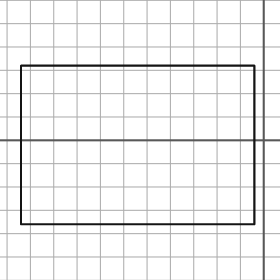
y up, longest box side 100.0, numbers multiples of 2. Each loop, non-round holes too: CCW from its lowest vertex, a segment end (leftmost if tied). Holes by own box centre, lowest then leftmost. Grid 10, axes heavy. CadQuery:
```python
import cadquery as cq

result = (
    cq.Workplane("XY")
    .moveTo(-104.0, -36.0)
    .lineTo(-4.0, -36.0)
    .lineTo(-4.0, 32.0)
    .lineTo(-104.0, 32.0)
    .close()
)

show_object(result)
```